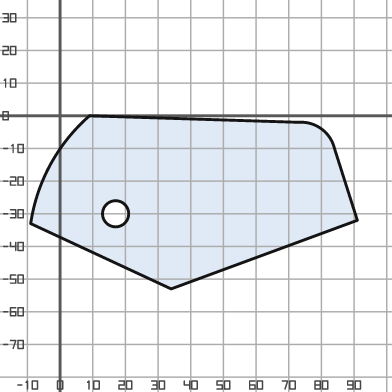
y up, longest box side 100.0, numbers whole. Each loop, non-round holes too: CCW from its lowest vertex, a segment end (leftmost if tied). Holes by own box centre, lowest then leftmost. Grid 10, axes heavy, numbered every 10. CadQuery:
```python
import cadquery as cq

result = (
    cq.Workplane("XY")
    .moveTo(34.0, -53.0)
    .lineTo(91.0, -32.0)
    .lineTo(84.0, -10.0)
    .threePointArc((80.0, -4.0), (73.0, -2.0))
    .lineTo(9.0, 0.0)
    .threePointArc((-3.0, -15.0), (-9.0, -33.0))
    .close()
    .moveTo(17.0, -30.0)
    .circle(4.0)
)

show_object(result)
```